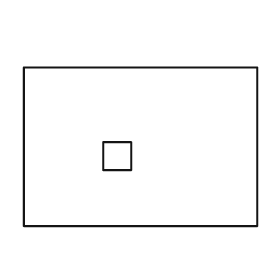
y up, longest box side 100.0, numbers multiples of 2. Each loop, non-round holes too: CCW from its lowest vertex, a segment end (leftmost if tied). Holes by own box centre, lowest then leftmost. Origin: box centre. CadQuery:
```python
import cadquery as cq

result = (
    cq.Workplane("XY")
    .moveTo(-50.0, -34.0)
    .lineTo(50.0, -34.0)
    .lineTo(50.0, 34.0)
    .lineTo(-50.0, 34.0)
    .close()
    .moveTo(-16.0, -10.0)
    .lineTo(-4.0, -10.0)
    .lineTo(-4.0, 2.0)
    .lineTo(-16.0, 2.0)
    .close()
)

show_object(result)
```